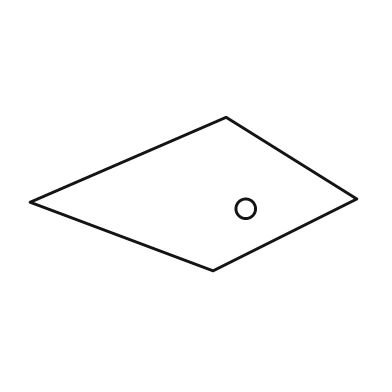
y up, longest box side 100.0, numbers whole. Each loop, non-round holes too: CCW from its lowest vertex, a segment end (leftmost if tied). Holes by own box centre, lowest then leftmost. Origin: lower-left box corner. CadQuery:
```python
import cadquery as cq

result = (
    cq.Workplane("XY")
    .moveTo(56.0, 0.0)
    .lineTo(100.0, 22.0)
    .lineTo(60.0, 47.0)
    .lineTo(0.0, 21.0)
    .close()
    .moveTo(66.0, 19.0)
    .circle(3.0)
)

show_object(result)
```